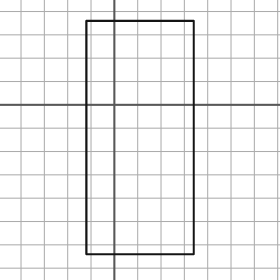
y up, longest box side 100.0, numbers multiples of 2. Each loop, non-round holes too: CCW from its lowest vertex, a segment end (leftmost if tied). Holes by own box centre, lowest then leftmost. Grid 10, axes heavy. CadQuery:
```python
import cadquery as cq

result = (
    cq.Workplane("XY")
    .moveTo(-12.0, -64.0)
    .lineTo(34.0, -64.0)
    .lineTo(34.0, 36.0)
    .lineTo(-12.0, 36.0)
    .close()
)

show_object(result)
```